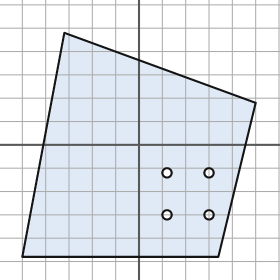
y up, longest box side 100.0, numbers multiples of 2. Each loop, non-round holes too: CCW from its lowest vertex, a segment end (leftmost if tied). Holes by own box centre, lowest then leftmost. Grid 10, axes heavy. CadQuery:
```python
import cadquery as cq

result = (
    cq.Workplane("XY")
    .moveTo(-50.0, -48.0)
    .lineTo(34.0, -48.0)
    .lineTo(50.0, 18.0)
    .lineTo(-32.0, 48.0)
    .close()
    .moveTo(12.0, -30.0)
    .circle(2.0)
    .moveTo(30.0, -30.0)
    .circle(2.0)
    .moveTo(12.0, -12.0)
    .circle(2.0)
    .moveTo(30.0, -12.0)
    .circle(2.0)
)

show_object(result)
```